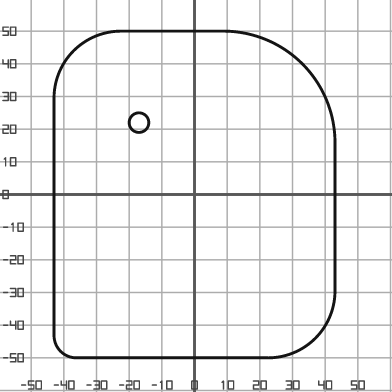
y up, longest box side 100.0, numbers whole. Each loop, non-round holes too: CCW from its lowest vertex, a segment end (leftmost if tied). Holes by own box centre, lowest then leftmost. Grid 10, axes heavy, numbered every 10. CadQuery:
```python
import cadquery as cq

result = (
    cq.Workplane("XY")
    .moveTo(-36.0, -50.0)
    .lineTo(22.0, -50.0)
    .threePointArc((37.0, -44.0), (43.0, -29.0))
    .lineTo(43.0, 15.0)
    .threePointArc((33.0, 40.0), (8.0, 50.0))
    .lineTo(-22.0, 50.0)
    .threePointArc((-37.0, 44.0), (-43.0, 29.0))
    .lineTo(-43.0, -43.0)
    .threePointArc((-41.0, -48.0), (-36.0, -50.0))
    .close()
    .moveTo(-17.0, 22.0)
    .circle(3.0)
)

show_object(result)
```